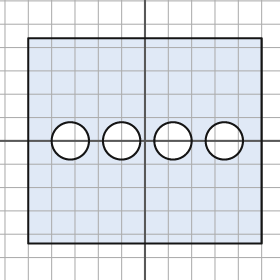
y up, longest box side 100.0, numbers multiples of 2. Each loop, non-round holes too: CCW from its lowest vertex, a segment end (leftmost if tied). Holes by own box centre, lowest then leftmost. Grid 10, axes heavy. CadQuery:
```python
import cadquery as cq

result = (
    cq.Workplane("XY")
    .moveTo(-50.0, -44.0)
    .lineTo(50.0, -44.0)
    .lineTo(50.0, 44.0)
    .lineTo(-50.0, 44.0)
    .close()
    .moveTo(-32.0, 0.0)
    .circle(8.0)
    .moveTo(-10.0, 0.0)
    .circle(8.0)
    .moveTo(12.0, 0.0)
    .circle(8.0)
    .moveTo(34.0, 0.0)
    .circle(8.0)
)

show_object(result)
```